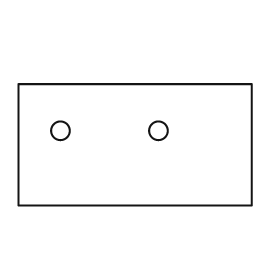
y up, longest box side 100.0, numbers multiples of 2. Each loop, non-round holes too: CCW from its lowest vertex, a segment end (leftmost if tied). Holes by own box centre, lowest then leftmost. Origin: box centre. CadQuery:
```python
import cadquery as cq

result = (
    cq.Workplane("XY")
    .moveTo(-50.0, -26.0)
    .lineTo(50.0, -26.0)
    .lineTo(50.0, 26.0)
    .lineTo(-50.0, 26.0)
    .close()
    .moveTo(-32.0, 6.0)
    .circle(4.0)
    .moveTo(10.0, 6.0)
    .circle(4.0)
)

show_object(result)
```